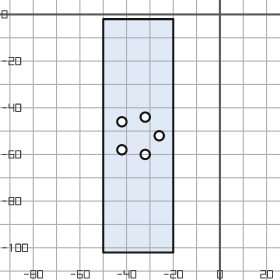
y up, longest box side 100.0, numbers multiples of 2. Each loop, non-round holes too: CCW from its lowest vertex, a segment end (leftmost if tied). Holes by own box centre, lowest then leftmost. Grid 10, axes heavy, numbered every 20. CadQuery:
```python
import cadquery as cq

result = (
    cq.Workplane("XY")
    .moveTo(-50.0, -102.0)
    .lineTo(-20.0, -102.0)
    .lineTo(-20.0, -2.0)
    .lineTo(-50.0, -2.0)
    .close()
    .moveTo(-32.0, -60.0)
    .circle(2.0)
    .moveTo(-42.0, -58.0)
    .circle(2.0)
    .moveTo(-26.0, -52.0)
    .circle(2.0)
    .moveTo(-42.0, -46.0)
    .circle(2.0)
    .moveTo(-32.0, -44.0)
    .circle(2.0)
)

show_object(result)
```